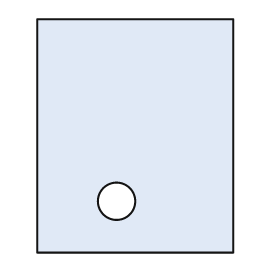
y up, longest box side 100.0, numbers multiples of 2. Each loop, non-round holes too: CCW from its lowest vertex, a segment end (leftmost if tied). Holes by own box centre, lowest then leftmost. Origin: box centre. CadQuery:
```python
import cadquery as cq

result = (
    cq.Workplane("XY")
    .moveTo(-42.0, -50.0)
    .lineTo(42.0, -50.0)
    .lineTo(42.0, 50.0)
    .lineTo(-42.0, 50.0)
    .close()
    .moveTo(-8.0, -28.0)
    .circle(8.0)
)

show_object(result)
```